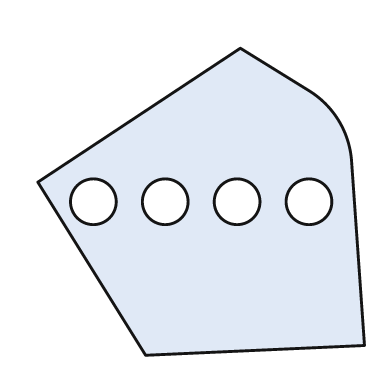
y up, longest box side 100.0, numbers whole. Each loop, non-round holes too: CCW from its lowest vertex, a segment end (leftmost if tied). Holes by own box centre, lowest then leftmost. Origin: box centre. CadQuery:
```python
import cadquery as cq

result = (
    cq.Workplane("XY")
    .moveTo(-17.0, -47.0)
    .lineTo(50.0, -44.0)
    .lineTo(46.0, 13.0)
    .threePointArc((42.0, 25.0), (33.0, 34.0))
    .lineTo(12.0, 47.0)
    .lineTo(-50.0, 6.0)
    .close()
    .moveTo(-33.0, 0.0)
    .circle(7.0)
    .moveTo(-11.0, 0.0)
    .circle(7.0)
    .moveTo(11.0, 0.0)
    .circle(7.0)
    .moveTo(33.0, 0.0)
    .circle(7.0)
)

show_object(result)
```